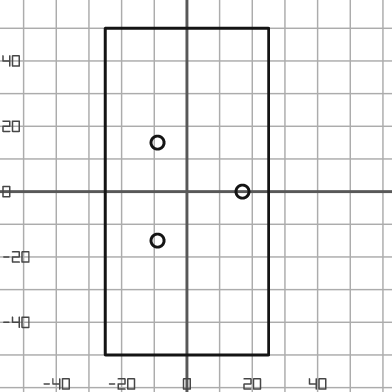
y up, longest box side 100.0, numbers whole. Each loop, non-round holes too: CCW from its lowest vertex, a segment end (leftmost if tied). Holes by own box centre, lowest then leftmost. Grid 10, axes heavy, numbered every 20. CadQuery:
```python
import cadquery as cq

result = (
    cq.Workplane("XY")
    .moveTo(-25.0, -50.0)
    .lineTo(25.0, -50.0)
    .lineTo(25.0, 50.0)
    .lineTo(-25.0, 50.0)
    .close()
    .moveTo(-9.0, -15.0)
    .circle(2.0)
    .moveTo(17.0, 0.0)
    .circle(2.0)
    .moveTo(-9.0, 15.0)
    .circle(2.0)
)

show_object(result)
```